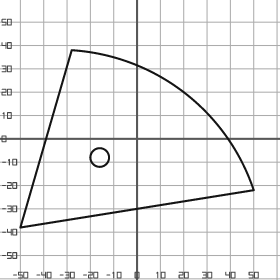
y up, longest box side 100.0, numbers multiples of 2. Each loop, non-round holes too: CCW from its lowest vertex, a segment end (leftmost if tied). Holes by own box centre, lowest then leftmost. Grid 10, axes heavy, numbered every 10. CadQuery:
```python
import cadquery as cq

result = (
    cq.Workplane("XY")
    .moveTo(-50.0, -38.0)
    .lineTo(50.0, -22.0)
    .threePointArc((20.0, 20.0), (-28.0, 38.0))
    .close()
    .moveTo(-16.0, -8.0)
    .circle(4.0)
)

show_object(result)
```